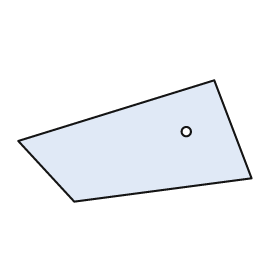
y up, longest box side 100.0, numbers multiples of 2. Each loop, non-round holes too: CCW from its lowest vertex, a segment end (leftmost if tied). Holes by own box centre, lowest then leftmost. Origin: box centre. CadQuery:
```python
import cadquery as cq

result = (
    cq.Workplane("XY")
    .moveTo(-26.0, -26.0)
    .lineTo(50.0, -16.0)
    .lineTo(34.0, 26.0)
    .lineTo(-50.0, 0.0)
    .close()
    .moveTo(22.0, 4.0)
    .circle(2.0)
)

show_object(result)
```